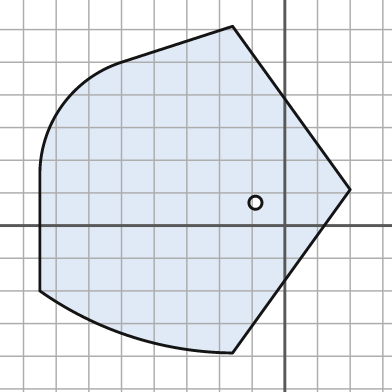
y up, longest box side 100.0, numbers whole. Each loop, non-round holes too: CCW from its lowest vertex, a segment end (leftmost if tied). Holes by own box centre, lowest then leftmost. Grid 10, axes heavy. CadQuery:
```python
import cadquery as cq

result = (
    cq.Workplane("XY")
    .moveTo(-16.0, -39.0)
    .lineTo(20.0, 11.0)
    .lineTo(-16.0, 61.0)
    .lineTo(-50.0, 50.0)
    .threePointArc((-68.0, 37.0), (-75.0, 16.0))
    .lineTo(-75.0, -20.0)
    .threePointArc((-47.0, -34.0), (-16.0, -39.0))
    .close()
    .moveTo(-9.0, 7.0)
    .circle(2.0)
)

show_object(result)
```